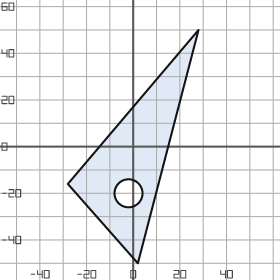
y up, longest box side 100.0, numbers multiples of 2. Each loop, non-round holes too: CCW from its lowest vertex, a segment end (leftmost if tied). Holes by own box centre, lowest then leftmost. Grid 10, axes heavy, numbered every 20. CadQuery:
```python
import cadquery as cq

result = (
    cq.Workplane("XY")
    .moveTo(2.0, -50.0)
    .lineTo(28.0, 50.0)
    .lineTo(-28.0, -16.0)
    .close()
    .moveTo(-2.0, -20.0)
    .circle(6.0)
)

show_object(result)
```